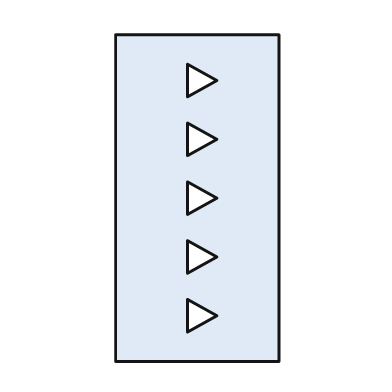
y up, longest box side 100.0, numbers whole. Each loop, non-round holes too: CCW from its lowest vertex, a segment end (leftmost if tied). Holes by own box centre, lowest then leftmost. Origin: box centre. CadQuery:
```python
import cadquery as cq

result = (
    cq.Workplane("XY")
    .moveTo(-25.0, -50.0)
    .lineTo(25.0, -50.0)
    .lineTo(25.0, 50.0)
    .lineTo(-25.0, 50.0)
    .close()
    .moveTo(-3.0, -41.0)
    .lineTo(6.0, -36.0)
    .lineTo(-3.0, -31.0)
    .close()
    .moveTo(-3.0, -23.0)
    .lineTo(6.0, -18.0)
    .lineTo(-3.0, -13.0)
    .close()
    .moveTo(-3.0, -5.0)
    .lineTo(6.0, 0.0)
    .lineTo(-3.0, 5.0)
    .close()
    .moveTo(-3.0, 13.0)
    .lineTo(6.0, 18.0)
    .lineTo(-3.0, 23.0)
    .close()
    .moveTo(-3.0, 31.0)
    .lineTo(6.0, 36.0)
    .lineTo(-3.0, 41.0)
    .close()
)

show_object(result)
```